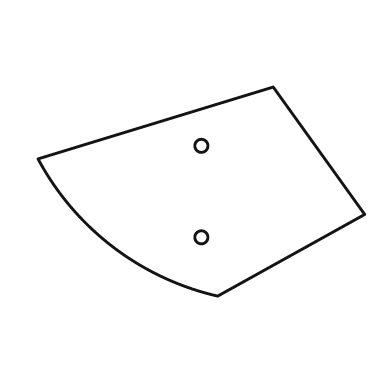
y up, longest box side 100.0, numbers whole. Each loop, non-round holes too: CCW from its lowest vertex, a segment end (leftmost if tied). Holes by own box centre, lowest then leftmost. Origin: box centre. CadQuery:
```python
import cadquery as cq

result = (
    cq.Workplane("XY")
    .moveTo(5.0, -32.0)
    .lineTo(50.0, -7.0)
    .lineTo(22.0, 32.0)
    .lineTo(-50.0, 10.0)
    .threePointArc((-27.0, -17.0), (5.0, -32.0))
    .close()
    .moveTo(0.0, -14.0)
    .circle(2.0)
    .moveTo(0.0, 14.0)
    .circle(2.0)
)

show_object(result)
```